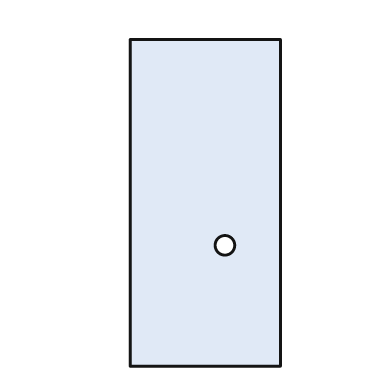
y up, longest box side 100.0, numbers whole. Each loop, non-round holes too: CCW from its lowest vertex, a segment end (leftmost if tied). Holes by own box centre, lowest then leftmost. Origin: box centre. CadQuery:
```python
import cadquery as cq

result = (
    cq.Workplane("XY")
    .moveTo(-23.0, -50.0)
    .lineTo(23.0, -50.0)
    .lineTo(23.0, 50.0)
    .lineTo(-23.0, 50.0)
    .close()
    .moveTo(6.0, -13.0)
    .circle(3.0)
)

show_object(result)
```